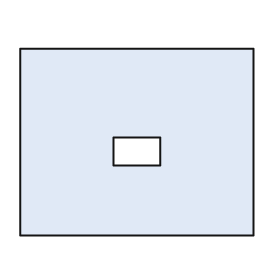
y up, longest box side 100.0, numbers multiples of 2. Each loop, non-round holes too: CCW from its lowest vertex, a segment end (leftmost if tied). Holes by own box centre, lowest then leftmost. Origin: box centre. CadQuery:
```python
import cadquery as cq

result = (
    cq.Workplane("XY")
    .moveTo(-50.0, -40.0)
    .lineTo(50.0, -40.0)
    .lineTo(50.0, 40.0)
    .lineTo(-50.0, 40.0)
    .close()
    .moveTo(-10.0, -10.0)
    .lineTo(10.0, -10.0)
    .lineTo(10.0, 2.0)
    .lineTo(-10.0, 2.0)
    .close()
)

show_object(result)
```